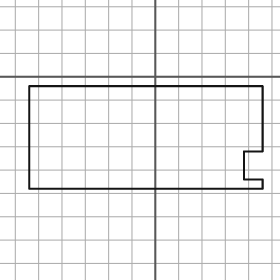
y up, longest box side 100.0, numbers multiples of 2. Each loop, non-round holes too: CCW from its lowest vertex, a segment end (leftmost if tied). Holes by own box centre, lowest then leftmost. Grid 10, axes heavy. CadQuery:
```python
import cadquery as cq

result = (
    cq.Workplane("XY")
    .moveTo(-54.0, -48.0)
    .lineTo(46.0, -48.0)
    .lineTo(46.0, -44.0)
    .lineTo(38.0, -44.0)
    .lineTo(38.0, -32.0)
    .lineTo(46.0, -32.0)
    .lineTo(46.0, -4.0)
    .lineTo(-54.0, -4.0)
    .close()
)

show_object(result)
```